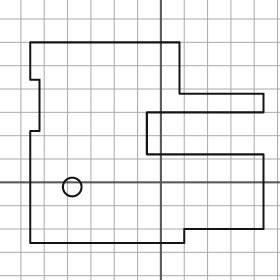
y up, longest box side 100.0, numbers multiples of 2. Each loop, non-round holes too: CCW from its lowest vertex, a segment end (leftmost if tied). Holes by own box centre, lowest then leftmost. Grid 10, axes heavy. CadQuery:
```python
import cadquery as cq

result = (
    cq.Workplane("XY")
    .moveTo(-56.0, -26.0)
    .lineTo(10.0, -26.0)
    .lineTo(10.0, -20.0)
    .lineTo(44.0, -20.0)
    .lineTo(44.0, 12.0)
    .lineTo(-6.0, 12.0)
    .lineTo(-6.0, 30.0)
    .lineTo(44.0, 30.0)
    .lineTo(44.0, 38.0)
    .lineTo(8.0, 38.0)
    .lineTo(8.0, 60.0)
    .lineTo(-56.0, 60.0)
    .lineTo(-56.0, 44.0)
    .lineTo(-52.0, 44.0)
    .lineTo(-52.0, 22.0)
    .lineTo(-56.0, 22.0)
    .close()
    .moveTo(-38.0, -2.0)
    .circle(4.0)
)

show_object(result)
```